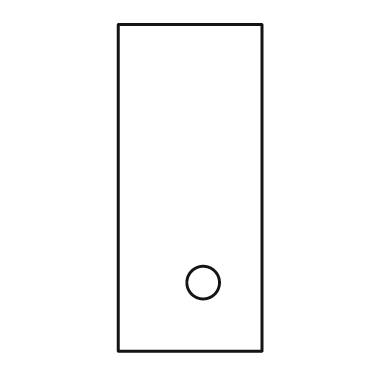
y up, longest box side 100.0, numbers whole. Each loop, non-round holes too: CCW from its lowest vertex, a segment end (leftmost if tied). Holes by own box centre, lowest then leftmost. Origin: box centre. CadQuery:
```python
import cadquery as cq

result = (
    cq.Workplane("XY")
    .moveTo(-22.0, -50.0)
    .lineTo(22.0, -50.0)
    .lineTo(22.0, 50.0)
    .lineTo(-22.0, 50.0)
    .close()
    .moveTo(4.0, -29.0)
    .circle(5.0)
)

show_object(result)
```